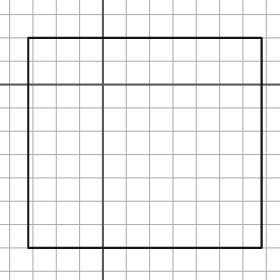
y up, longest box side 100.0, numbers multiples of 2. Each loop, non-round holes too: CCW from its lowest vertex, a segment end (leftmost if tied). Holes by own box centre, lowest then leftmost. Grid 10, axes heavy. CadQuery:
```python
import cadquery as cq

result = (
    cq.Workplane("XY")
    .moveTo(-32.0, -70.0)
    .lineTo(68.0, -70.0)
    .lineTo(68.0, 20.0)
    .lineTo(-32.0, 20.0)
    .close()
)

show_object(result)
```